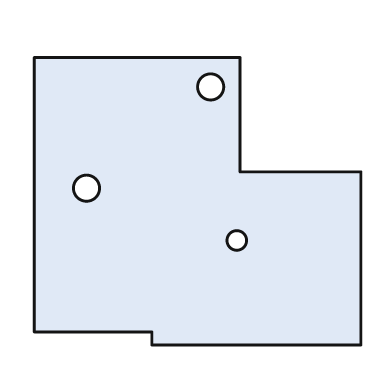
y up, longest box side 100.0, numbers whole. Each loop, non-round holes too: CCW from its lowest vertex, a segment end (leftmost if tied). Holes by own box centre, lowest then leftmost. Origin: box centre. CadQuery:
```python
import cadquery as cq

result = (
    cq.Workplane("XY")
    .moveTo(-14.0, -44.0)
    .lineTo(50.0, -44.0)
    .lineTo(50.0, 9.0)
    .lineTo(13.0, 9.0)
    .lineTo(13.0, 44.0)
    .lineTo(-50.0, 44.0)
    .lineTo(-50.0, -40.0)
    .lineTo(-14.0, -40.0)
    .close()
    .moveTo(12.0, -12.0)
    .circle(3.0)
    .moveTo(-34.0, 4.0)
    .circle(4.0)
    .moveTo(4.0, 35.0)
    .circle(4.0)
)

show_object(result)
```